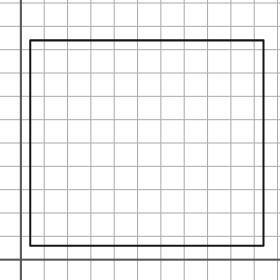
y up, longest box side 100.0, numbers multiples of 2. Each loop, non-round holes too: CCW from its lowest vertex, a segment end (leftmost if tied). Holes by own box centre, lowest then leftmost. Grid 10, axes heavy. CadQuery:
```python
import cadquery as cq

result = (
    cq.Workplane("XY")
    .moveTo(4.0, 6.0)
    .lineTo(104.0, 6.0)
    .lineTo(104.0, 94.0)
    .lineTo(4.0, 94.0)
    .close()
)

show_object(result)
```